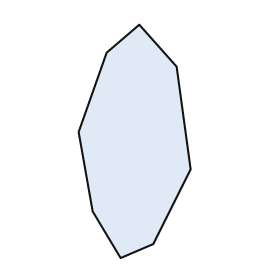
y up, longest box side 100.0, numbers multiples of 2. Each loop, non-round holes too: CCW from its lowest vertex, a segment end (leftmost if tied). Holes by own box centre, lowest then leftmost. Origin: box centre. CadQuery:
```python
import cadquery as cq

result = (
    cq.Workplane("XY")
    .moveTo(-6.0, -50.0)
    .lineTo(8.0, -44.0)
    .lineTo(24.0, -12.0)
    .lineTo(18.0, 32.0)
    .lineTo(2.0, 50.0)
    .lineTo(-12.0, 38.0)
    .lineTo(-24.0, 4.0)
    .lineTo(-18.0, -30.0)
    .close()
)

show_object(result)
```